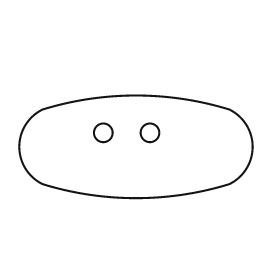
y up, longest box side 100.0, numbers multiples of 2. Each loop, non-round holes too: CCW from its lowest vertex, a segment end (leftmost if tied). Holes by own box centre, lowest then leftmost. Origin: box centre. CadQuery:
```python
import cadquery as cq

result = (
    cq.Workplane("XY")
    .moveTo(-40.0, -16.0)
    .threePointArc((0.0, -22.0), (40.0, -16.0))
    .threePointArc((50.0, 0.0), (40.0, 16.0))
    .threePointArc((0.0, 22.0), (-40.0, 16.0))
    .threePointArc((-50.0, 0.0), (-40.0, -16.0))
    .close()
    .moveTo(-14.0, 6.0)
    .circle(4.0)
    .moveTo(6.0, 6.0)
    .circle(4.0)
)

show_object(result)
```